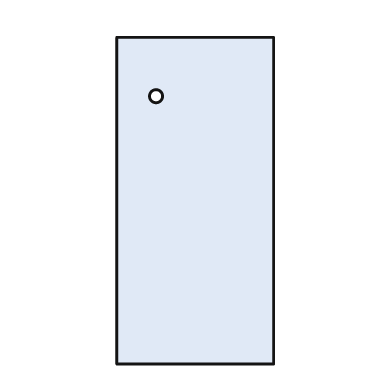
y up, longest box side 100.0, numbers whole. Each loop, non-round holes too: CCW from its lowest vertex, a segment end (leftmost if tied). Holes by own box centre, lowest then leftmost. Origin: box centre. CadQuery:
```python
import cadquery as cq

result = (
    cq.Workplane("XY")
    .moveTo(-24.0, -50.0)
    .lineTo(24.0, -50.0)
    .lineTo(24.0, 50.0)
    .lineTo(-24.0, 50.0)
    .close()
    .moveTo(-12.0, 32.0)
    .circle(2.0)
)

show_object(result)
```